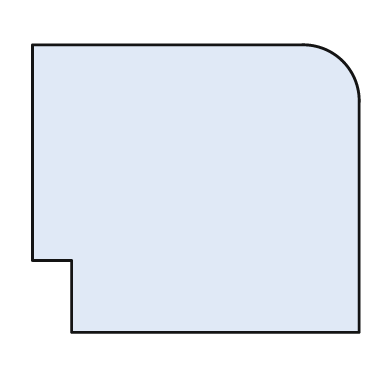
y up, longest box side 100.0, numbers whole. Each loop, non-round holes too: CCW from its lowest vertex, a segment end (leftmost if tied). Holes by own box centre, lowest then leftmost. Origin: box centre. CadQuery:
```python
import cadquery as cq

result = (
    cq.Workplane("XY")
    .moveTo(-38.0, -44.0)
    .lineTo(50.0, -44.0)
    .lineTo(50.0, 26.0)
    .threePointArc((45.0, 39.0), (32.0, 44.0))
    .lineTo(-50.0, 44.0)
    .lineTo(-50.0, -22.0)
    .lineTo(-38.0, -22.0)
    .close()
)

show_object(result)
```